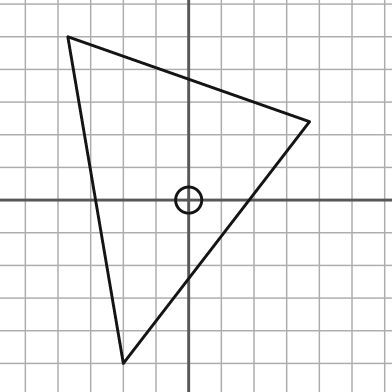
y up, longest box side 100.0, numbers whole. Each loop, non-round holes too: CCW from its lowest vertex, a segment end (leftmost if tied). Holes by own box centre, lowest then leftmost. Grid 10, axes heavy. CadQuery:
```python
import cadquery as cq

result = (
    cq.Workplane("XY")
    .moveTo(-20.0, -50.0)
    .lineTo(37.0, 24.0)
    .lineTo(-37.0, 50.0)
    .close()
    .moveTo(0.0, 0.0)
    .circle(4.0)
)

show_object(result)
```